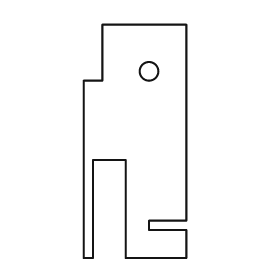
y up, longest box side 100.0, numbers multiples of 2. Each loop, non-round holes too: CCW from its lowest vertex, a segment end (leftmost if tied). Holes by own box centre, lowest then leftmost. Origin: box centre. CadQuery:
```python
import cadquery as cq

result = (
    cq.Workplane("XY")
    .moveTo(-22.0, -50.0)
    .lineTo(-18.0, -50.0)
    .lineTo(-18.0, -8.0)
    .lineTo(-4.0, -8.0)
    .lineTo(-4.0, -50.0)
    .lineTo(22.0, -50.0)
    .lineTo(22.0, -38.0)
    .lineTo(6.0, -38.0)
    .lineTo(6.0, -34.0)
    .lineTo(22.0, -34.0)
    .lineTo(22.0, 50.0)
    .lineTo(-14.0, 50.0)
    .lineTo(-14.0, 26.0)
    .lineTo(-22.0, 26.0)
    .close()
    .moveTo(6.0, 30.0)
    .circle(4.0)
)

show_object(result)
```